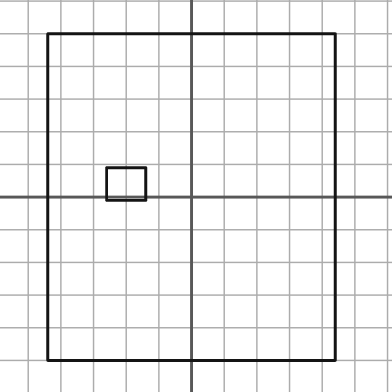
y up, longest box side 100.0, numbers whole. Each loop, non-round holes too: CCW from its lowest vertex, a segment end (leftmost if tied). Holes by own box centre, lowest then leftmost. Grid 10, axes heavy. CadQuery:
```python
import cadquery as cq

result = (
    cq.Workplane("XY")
    .moveTo(-44.0, -50.0)
    .lineTo(44.0, -50.0)
    .lineTo(44.0, 50.0)
    .lineTo(-44.0, 50.0)
    .close()
    .moveTo(-26.0, -1.0)
    .lineTo(-14.0, -1.0)
    .lineTo(-14.0, 9.0)
    .lineTo(-26.0, 9.0)
    .close()
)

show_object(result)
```